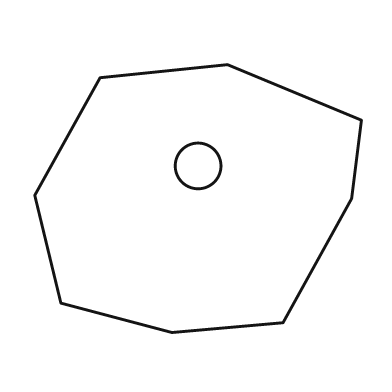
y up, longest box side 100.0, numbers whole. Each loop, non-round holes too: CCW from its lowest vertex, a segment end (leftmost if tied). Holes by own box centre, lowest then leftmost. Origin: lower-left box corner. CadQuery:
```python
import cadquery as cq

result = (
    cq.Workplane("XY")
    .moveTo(42.0, 0.0)
    .lineTo(76.0, 3.0)
    .lineTo(97.0, 41.0)
    .lineTo(100.0, 65.0)
    .lineTo(59.0, 82.0)
    .lineTo(20.0, 78.0)
    .lineTo(0.0, 42.0)
    .lineTo(8.0, 9.0)
    .close()
    .moveTo(50.0, 51.0)
    .circle(7.0)
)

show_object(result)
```